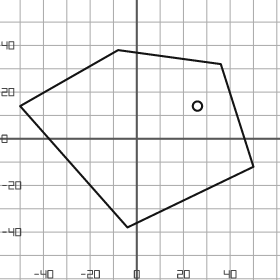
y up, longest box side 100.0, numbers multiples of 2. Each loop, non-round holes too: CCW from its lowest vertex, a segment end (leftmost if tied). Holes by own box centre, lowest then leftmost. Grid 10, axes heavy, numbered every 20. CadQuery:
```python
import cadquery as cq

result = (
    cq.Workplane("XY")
    .moveTo(-4.0, -38.0)
    .lineTo(50.0, -12.0)
    .lineTo(36.0, 32.0)
    .lineTo(-8.0, 38.0)
    .lineTo(-50.0, 14.0)
    .close()
    .moveTo(26.0, 14.0)
    .circle(2.0)
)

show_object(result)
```